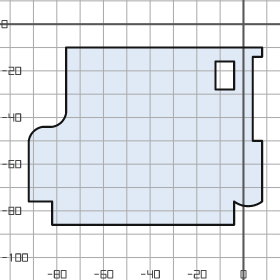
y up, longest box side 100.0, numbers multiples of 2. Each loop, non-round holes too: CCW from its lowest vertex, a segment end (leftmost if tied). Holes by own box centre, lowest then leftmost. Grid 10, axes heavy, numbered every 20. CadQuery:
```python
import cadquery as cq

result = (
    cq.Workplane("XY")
    .moveTo(-82.0, -86.0)
    .lineTo(-4.0, -86.0)
    .lineTo(-4.0, -76.0)
    .threePointArc((2.0, -78.0), (8.0, -76.0))
    .lineTo(8.0, -50.0)
    .lineTo(4.0, -50.0)
    .lineTo(4.0, -14.0)
    .lineTo(8.0, -14.0)
    .lineTo(8.0, -10.0)
    .lineTo(-76.0, -10.0)
    .lineTo(-76.0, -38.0)
    .threePointArc((-78.0, -42.0), (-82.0, -44.0))
    .lineTo(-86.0, -44.0)
    .threePointArc((-90.0, -46.0), (-92.0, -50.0))
    .lineTo(-92.0, -76.0)
    .lineTo(-82.0, -76.0)
    .close()
    .moveTo(-12.0, -28.0)
    .lineTo(-4.0, -28.0)
    .lineTo(-4.0, -16.0)
    .lineTo(-12.0, -16.0)
    .close()
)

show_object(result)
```